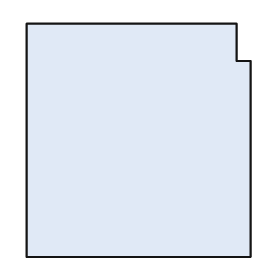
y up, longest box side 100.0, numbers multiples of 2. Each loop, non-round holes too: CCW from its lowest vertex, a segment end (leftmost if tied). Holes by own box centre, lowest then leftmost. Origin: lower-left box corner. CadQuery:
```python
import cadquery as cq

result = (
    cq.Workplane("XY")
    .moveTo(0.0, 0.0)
    .lineTo(96.0, 0.0)
    .lineTo(96.0, 84.0)
    .lineTo(90.0, 84.0)
    .lineTo(90.0, 100.0)
    .lineTo(0.0, 100.0)
    .close()
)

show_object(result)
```